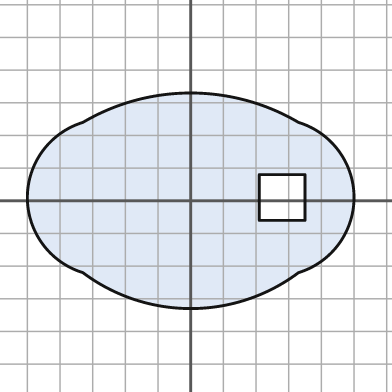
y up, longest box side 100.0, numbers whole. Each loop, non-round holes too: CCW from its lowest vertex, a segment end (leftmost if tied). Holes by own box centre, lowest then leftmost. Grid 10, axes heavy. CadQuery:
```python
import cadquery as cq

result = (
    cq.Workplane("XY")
    .moveTo(-33.0, -22.0)
    .threePointArc((0.0, -33.0), (33.0, -22.0))
    .threePointArc((50.0, 1.0), (33.0, 24.0))
    .threePointArc((0.0, 33.0), (-33.0, 24.0))
    .threePointArc((-50.0, 1.0), (-33.0, -22.0))
    .close()
    .moveTo(21.0, -6.0)
    .lineTo(35.0, -6.0)
    .lineTo(35.0, 8.0)
    .lineTo(21.0, 8.0)
    .close()
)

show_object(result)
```